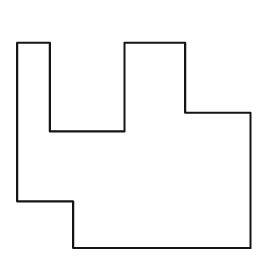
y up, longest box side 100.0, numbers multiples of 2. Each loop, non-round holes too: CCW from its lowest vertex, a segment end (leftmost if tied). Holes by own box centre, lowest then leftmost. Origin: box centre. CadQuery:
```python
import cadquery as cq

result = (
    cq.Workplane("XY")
    .moveTo(-26.0, -44.0)
    .lineTo(50.0, -44.0)
    .lineTo(50.0, 14.0)
    .lineTo(22.0, 14.0)
    .lineTo(22.0, 44.0)
    .lineTo(-4.0, 44.0)
    .lineTo(-4.0, 6.0)
    .lineTo(-36.0, 6.0)
    .lineTo(-36.0, 44.0)
    .lineTo(-50.0, 44.0)
    .lineTo(-50.0, -24.0)
    .lineTo(-26.0, -24.0)
    .close()
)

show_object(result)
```